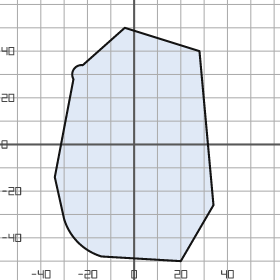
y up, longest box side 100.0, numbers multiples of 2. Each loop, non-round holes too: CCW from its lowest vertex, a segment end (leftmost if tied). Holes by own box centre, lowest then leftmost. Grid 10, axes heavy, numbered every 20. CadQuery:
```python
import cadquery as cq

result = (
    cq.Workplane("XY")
    .moveTo(20.0, -50.0)
    .lineTo(34.0, -26.0)
    .lineTo(28.0, 40.0)
    .lineTo(-4.0, 50.0)
    .lineTo(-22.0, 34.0)
    .threePointArc((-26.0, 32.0), (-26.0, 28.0))
    .lineTo(-34.0, -14.0)
    .lineTo(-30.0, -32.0)
    .threePointArc((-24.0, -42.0), (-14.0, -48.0))
    .close()
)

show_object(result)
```